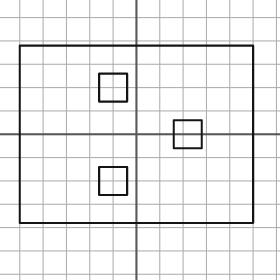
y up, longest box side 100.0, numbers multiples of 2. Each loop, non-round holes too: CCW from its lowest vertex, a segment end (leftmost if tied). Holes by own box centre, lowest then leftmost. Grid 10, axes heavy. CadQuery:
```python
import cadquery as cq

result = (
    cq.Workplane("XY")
    .moveTo(-50.0, -38.0)
    .lineTo(50.0, -38.0)
    .lineTo(50.0, 38.0)
    .lineTo(-50.0, 38.0)
    .close()
    .moveTo(-16.0, -26.0)
    .lineTo(-4.0, -26.0)
    .lineTo(-4.0, -14.0)
    .lineTo(-16.0, -14.0)
    .close()
    .moveTo(16.0, -6.0)
    .lineTo(28.0, -6.0)
    .lineTo(28.0, 6.0)
    .lineTo(16.0, 6.0)
    .close()
    .moveTo(-16.0, 14.0)
    .lineTo(-4.0, 14.0)
    .lineTo(-4.0, 26.0)
    .lineTo(-16.0, 26.0)
    .close()
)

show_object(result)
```